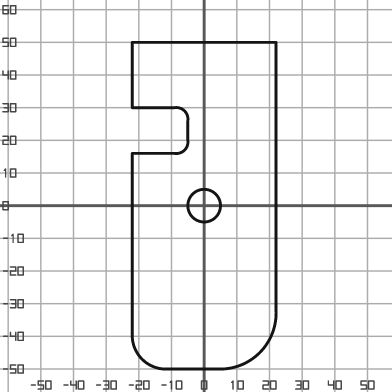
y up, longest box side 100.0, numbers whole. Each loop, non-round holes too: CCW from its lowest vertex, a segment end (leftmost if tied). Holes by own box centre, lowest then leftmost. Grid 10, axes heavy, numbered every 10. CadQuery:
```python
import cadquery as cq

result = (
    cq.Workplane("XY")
    .moveTo(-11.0, -50.0)
    .lineTo(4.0, -50.0)
    .threePointArc((17.0, -45.0), (22.0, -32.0))
    .lineTo(22.0, 50.0)
    .lineTo(-22.0, 50.0)
    .lineTo(-22.0, 30.0)
    .lineTo(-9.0, 30.0)
    .threePointArc((-6.0, 29.0), (-5.0, 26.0))
    .lineTo(-5.0, 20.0)
    .threePointArc((-6.0, 17.0), (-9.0, 16.0))
    .lineTo(-22.0, 16.0)
    .lineTo(-22.0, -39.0)
    .threePointArc((-19.0, -47.0), (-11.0, -50.0))
    .close()
    .moveTo(0.0, 0.0)
    .circle(5.0)
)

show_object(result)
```